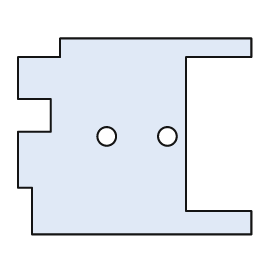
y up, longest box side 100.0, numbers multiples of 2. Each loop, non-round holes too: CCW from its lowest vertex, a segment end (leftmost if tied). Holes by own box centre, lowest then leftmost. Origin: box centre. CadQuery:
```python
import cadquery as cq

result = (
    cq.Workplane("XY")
    .moveTo(-44.0, -42.0)
    .lineTo(50.0, -42.0)
    .lineTo(50.0, -32.0)
    .lineTo(22.0, -32.0)
    .lineTo(22.0, 34.0)
    .lineTo(50.0, 34.0)
    .lineTo(50.0, 42.0)
    .lineTo(-32.0, 42.0)
    .lineTo(-32.0, 34.0)
    .lineTo(-50.0, 34.0)
    .lineTo(-50.0, 16.0)
    .lineTo(-36.0, 16.0)
    .lineTo(-36.0, 2.0)
    .lineTo(-50.0, 2.0)
    .lineTo(-50.0, -22.0)
    .lineTo(-44.0, -22.0)
    .close()
    .moveTo(-12.0, 0.0)
    .circle(4.0)
    .moveTo(14.0, 0.0)
    .circle(4.0)
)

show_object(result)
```